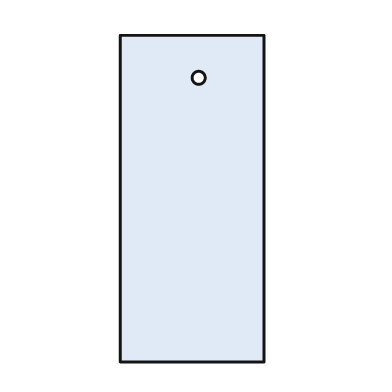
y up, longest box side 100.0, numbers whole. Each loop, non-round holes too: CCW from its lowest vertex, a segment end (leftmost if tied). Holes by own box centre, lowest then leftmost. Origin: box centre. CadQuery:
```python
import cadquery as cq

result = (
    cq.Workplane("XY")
    .moveTo(-22.0, -50.0)
    .lineTo(22.0, -50.0)
    .lineTo(22.0, 50.0)
    .lineTo(-22.0, 50.0)
    .close()
    .moveTo(2.0, 37.0)
    .circle(2.0)
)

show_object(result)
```